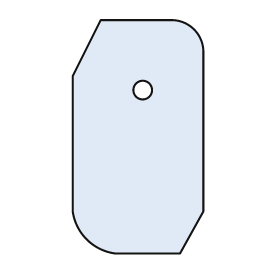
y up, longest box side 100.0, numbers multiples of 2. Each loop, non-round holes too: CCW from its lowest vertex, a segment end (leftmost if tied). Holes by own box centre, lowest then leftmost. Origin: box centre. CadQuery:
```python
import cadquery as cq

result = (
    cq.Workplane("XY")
    .moveTo(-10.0, -50.0)
    .lineTo(18.0, -50.0)
    .lineTo(28.0, -32.0)
    .lineTo(28.0, 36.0)
    .threePointArc((24.0, 46.0), (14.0, 50.0))
    .lineTo(-16.0, 50.0)
    .lineTo(-28.0, 26.0)
    .lineTo(-28.0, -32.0)
    .threePointArc((-22.0, -44.0), (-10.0, -50.0))
    .close()
    .moveTo(2.0, 20.0)
    .circle(4.0)
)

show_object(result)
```